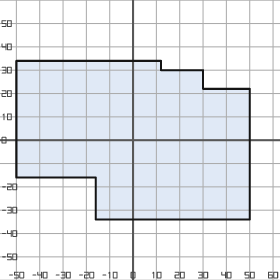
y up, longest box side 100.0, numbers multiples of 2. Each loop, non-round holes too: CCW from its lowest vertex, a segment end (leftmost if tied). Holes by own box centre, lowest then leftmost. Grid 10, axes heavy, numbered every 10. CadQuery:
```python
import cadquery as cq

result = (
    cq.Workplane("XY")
    .moveTo(-16.0, -34.0)
    .lineTo(50.0, -34.0)
    .lineTo(50.0, 22.0)
    .lineTo(30.0, 22.0)
    .lineTo(30.0, 30.0)
    .lineTo(12.0, 30.0)
    .lineTo(12.0, 34.0)
    .lineTo(-50.0, 34.0)
    .lineTo(-50.0, -16.0)
    .lineTo(-16.0, -16.0)
    .close()
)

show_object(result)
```